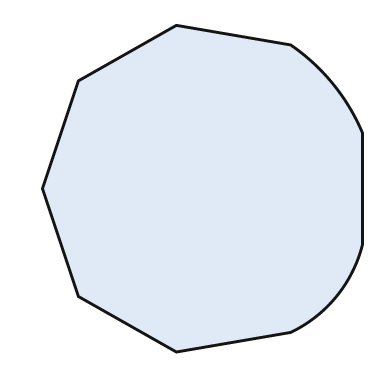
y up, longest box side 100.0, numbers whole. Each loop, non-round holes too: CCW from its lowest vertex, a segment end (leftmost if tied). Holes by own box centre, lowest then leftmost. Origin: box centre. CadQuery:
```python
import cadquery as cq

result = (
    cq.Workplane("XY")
    .moveTo(-8.0, -50.0)
    .lineTo(27.0, -44.0)
    .threePointArc((41.0, -33.0), (49.0, -17.0))
    .lineTo(49.0, 17.0)
    .threePointArc((40.0, 32.0), (27.0, 44.0))
    .lineTo(-8.0, 50.0)
    .lineTo(-38.0, 33.0)
    .lineTo(-49.0, 0.0)
    .lineTo(-38.0, -33.0)
    .close()
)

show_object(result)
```